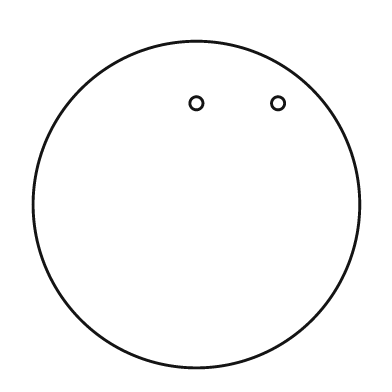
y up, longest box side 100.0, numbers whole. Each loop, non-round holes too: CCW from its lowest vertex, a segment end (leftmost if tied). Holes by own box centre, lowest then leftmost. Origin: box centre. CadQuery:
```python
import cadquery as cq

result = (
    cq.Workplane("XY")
    .moveTo(0.0, 0.0)
    .circle(50.0)
    .moveTo(0.0, 31.0)
    .circle(2.0)
    .moveTo(25.0, 31.0)
    .circle(2.0)
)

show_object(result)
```